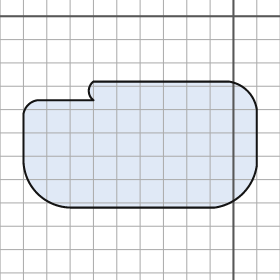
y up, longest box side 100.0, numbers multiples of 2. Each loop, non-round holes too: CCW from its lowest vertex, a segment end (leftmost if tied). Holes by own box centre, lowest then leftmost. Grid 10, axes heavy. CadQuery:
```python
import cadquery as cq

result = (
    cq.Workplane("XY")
    .moveTo(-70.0, -82.0)
    .lineTo(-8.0, -82.0)
    .threePointArc((4.0, -76.0), (10.0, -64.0))
    .lineTo(10.0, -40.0)
    .threePointArc((6.0, -32.0), (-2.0, -28.0))
    .lineTo(-60.0, -28.0)
    .threePointArc((-62.0, -32.0), (-60.0, -36.0))
    .lineTo(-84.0, -36.0)
    .threePointArc((-88.0, -38.0), (-90.0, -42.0))
    .lineTo(-90.0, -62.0)
    .threePointArc((-84.0, -76.0), (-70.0, -82.0))
    .close()
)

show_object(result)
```